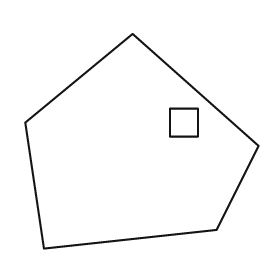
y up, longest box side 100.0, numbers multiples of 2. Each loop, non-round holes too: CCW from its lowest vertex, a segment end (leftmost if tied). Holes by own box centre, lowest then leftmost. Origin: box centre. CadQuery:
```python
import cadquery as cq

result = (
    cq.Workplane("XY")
    .moveTo(-42.0, -46.0)
    .lineTo(32.0, -38.0)
    .lineTo(50.0, -2.0)
    .lineTo(-4.0, 46.0)
    .lineTo(-50.0, 8.0)
    .close()
    .moveTo(12.0, 2.0)
    .lineTo(24.0, 2.0)
    .lineTo(24.0, 14.0)
    .lineTo(12.0, 14.0)
    .close()
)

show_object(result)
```